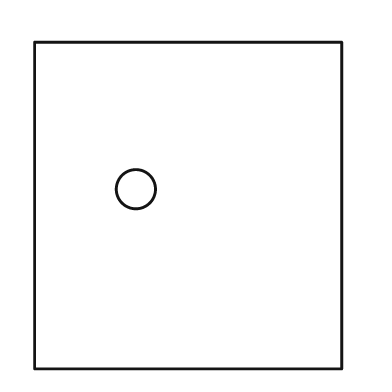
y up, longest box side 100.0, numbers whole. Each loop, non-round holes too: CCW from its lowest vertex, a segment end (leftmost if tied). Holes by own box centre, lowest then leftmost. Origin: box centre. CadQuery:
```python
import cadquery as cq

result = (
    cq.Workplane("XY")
    .moveTo(-47.0, -50.0)
    .lineTo(47.0, -50.0)
    .lineTo(47.0, 50.0)
    .lineTo(-47.0, 50.0)
    .close()
    .moveTo(-16.0, 5.0)
    .circle(6.0)
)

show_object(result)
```